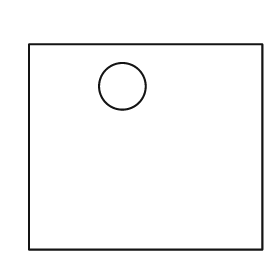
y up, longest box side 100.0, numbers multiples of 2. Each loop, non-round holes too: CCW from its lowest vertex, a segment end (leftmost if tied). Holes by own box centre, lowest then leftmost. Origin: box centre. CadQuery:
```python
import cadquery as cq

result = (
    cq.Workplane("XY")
    .moveTo(-50.0, -44.0)
    .lineTo(50.0, -44.0)
    .lineTo(50.0, 44.0)
    .lineTo(-50.0, 44.0)
    .close()
    .moveTo(-10.0, 26.0)
    .circle(10.0)
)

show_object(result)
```